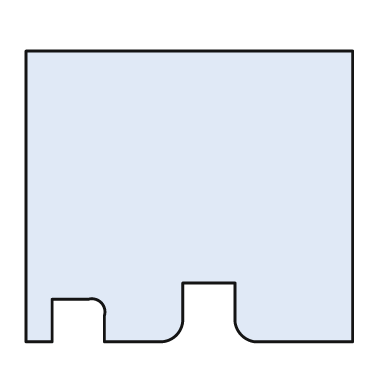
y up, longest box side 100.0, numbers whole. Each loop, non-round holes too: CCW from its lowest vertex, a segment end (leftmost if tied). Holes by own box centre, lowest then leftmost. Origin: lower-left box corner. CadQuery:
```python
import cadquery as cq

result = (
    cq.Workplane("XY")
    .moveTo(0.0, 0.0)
    .lineTo(8.0, 0.0)
    .lineTo(8.0, 13.0)
    .lineTo(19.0, 13.0)
    .threePointArc((23.0, 12.0), (24.0, 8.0))
    .lineTo(24.0, 0.0)
    .lineTo(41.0, 0.0)
    .threePointArc((46.0, 2.0), (48.0, 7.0))
    .lineTo(48.0, 18.0)
    .lineTo(64.0, 18.0)
    .lineTo(64.0, 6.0)
    .threePointArc((66.0, 2.0), (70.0, 0.0))
    .lineTo(100.0, 0.0)
    .lineTo(100.0, 89.0)
    .lineTo(0.0, 89.0)
    .close()
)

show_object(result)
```